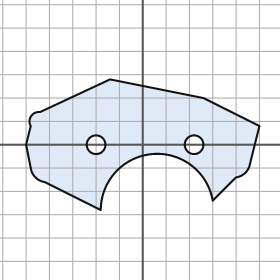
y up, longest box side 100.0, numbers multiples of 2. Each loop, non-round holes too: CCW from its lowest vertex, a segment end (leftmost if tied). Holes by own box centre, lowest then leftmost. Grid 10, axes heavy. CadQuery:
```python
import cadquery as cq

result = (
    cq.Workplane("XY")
    .moveTo(-18.0, -28.0)
    .threePointArc((4.0, -4.0), (30.0, -24.0))
    .lineTo(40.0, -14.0)
    .threePointArc((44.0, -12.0), (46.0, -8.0))
    .lineTo(50.0, 8.0)
    .lineTo(26.0, 20.0)
    .lineTo(-14.0, 28.0)
    .lineTo(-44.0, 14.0)
    .threePointArc((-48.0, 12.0), (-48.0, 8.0))
    .lineTo(-50.0, 0.0)
    .lineTo(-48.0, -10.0)
    .threePointArc((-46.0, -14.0), (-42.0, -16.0))
    .close()
    .moveTo(-20.0, 0.0)
    .circle(4.0)
    .moveTo(22.0, 0.0)
    .circle(4.0)
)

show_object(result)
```